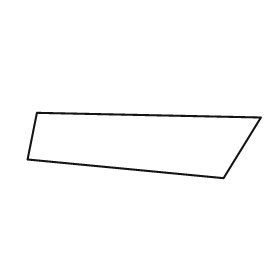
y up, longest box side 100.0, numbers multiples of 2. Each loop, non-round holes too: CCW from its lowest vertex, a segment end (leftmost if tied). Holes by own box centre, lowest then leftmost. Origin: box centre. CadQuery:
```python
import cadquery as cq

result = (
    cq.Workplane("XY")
    .moveTo(34.0, -14.0)
    .lineTo(50.0, 12.0)
    .lineTo(-46.0, 14.0)
    .lineTo(-50.0, -6.0)
    .close()
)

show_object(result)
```